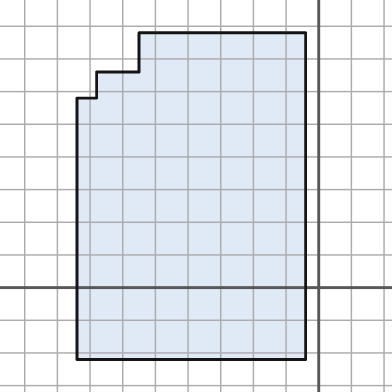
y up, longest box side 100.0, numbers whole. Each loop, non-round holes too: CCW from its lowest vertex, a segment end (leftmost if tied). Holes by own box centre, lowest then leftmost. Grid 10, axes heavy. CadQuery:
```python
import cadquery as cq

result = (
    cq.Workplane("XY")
    .moveTo(-74.0, -22.0)
    .lineTo(-4.0, -22.0)
    .lineTo(-4.0, 78.0)
    .lineTo(-55.0, 78.0)
    .lineTo(-55.0, 66.0)
    .lineTo(-68.0, 66.0)
    .lineTo(-68.0, 58.0)
    .lineTo(-74.0, 58.0)
    .close()
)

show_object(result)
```